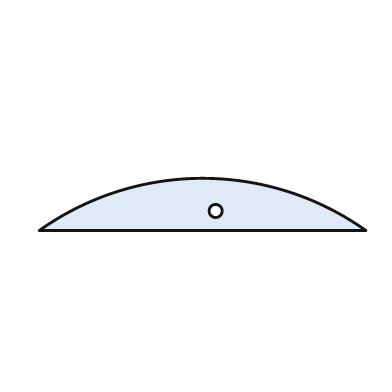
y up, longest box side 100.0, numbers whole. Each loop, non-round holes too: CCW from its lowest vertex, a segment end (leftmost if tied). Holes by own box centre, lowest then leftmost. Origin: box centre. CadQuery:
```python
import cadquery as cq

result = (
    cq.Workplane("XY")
    .moveTo(-50.0, -8.0)
    .lineTo(50.0, -8.0)
    .threePointArc((0.0, 8.0), (-50.0, -8.0))
    .close()
    .moveTo(4.0, -2.0)
    .circle(2.0)
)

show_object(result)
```